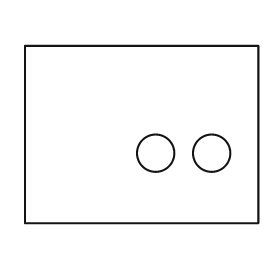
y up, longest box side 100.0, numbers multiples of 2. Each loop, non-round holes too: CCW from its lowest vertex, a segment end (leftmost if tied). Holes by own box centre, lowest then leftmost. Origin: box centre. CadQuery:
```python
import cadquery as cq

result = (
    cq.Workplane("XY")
    .moveTo(-50.0, -38.0)
    .lineTo(50.0, -38.0)
    .lineTo(50.0, 38.0)
    .lineTo(-50.0, 38.0)
    .close()
    .moveTo(6.0, -8.0)
    .circle(8.0)
    .moveTo(30.0, -8.0)
    .circle(8.0)
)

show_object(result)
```